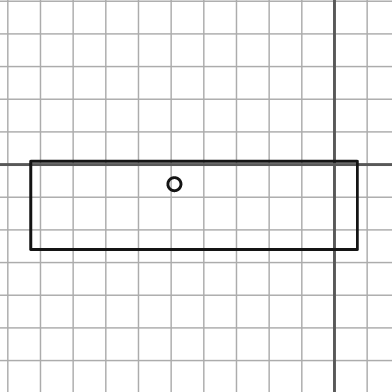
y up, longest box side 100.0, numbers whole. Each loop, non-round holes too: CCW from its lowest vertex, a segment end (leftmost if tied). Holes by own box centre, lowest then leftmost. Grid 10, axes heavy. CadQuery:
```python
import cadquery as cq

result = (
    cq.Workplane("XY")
    .moveTo(-93.0, -26.0)
    .lineTo(7.0, -26.0)
    .lineTo(7.0, 1.0)
    .lineTo(-93.0, 1.0)
    .close()
    .moveTo(-49.0, -6.0)
    .circle(2.0)
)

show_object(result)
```